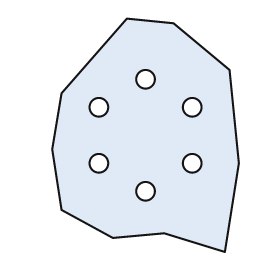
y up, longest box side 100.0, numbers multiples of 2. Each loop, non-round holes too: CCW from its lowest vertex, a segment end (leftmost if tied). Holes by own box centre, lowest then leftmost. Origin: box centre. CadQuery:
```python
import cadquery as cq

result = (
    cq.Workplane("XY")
    .moveTo(34.0, -50.0)
    .lineTo(40.0, -12.0)
    .lineTo(36.0, 28.0)
    .lineTo(12.0, 48.0)
    .lineTo(-8.0, 50.0)
    .lineTo(-36.0, 18.0)
    .lineTo(-40.0, -6.0)
    .lineTo(-36.0, -32.0)
    .lineTo(-14.0, -44.0)
    .lineTo(8.0, -42.0)
    .close()
    .moveTo(0.0, -24.0)
    .circle(4.0)
    .moveTo(-20.0, -12.0)
    .circle(4.0)
    .moveTo(20.0, -12.0)
    .circle(4.0)
    .moveTo(-20.0, 12.0)
    .circle(4.0)
    .moveTo(20.0, 12.0)
    .circle(4.0)
    .moveTo(0.0, 24.0)
    .circle(4.0)
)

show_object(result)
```